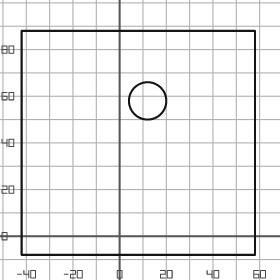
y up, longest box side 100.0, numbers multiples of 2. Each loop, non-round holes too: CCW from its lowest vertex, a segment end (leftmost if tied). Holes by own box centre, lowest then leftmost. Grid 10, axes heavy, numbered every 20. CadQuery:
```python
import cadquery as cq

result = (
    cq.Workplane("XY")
    .moveTo(-42.0, -8.0)
    .lineTo(58.0, -8.0)
    .lineTo(58.0, 88.0)
    .lineTo(-42.0, 88.0)
    .close()
    .moveTo(12.0, 58.0)
    .circle(8.0)
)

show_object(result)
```